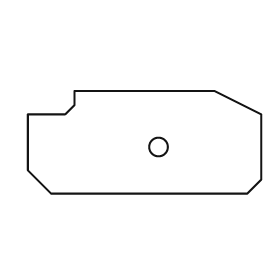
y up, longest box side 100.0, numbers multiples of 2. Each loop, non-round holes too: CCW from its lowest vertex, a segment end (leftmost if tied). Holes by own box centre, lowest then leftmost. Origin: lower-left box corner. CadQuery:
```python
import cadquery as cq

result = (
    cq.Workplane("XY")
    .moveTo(10.0, 0.0)
    .lineTo(94.0, 0.0)
    .lineTo(100.0, 6.0)
    .lineTo(100.0, 34.0)
    .lineTo(80.0, 44.0)
    .lineTo(20.0, 44.0)
    .lineTo(20.0, 38.0)
    .lineTo(16.0, 34.0)
    .lineTo(0.0, 34.0)
    .lineTo(0.0, 10.0)
    .close()
    .moveTo(56.0, 20.0)
    .circle(4.0)
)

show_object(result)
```